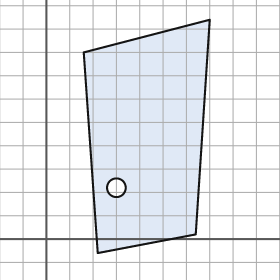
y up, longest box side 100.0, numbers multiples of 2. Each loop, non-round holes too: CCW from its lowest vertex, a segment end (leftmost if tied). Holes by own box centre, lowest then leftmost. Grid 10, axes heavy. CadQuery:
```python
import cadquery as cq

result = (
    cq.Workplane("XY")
    .moveTo(22.0, -6.0)
    .lineTo(64.0, 2.0)
    .lineTo(70.0, 94.0)
    .lineTo(16.0, 80.0)
    .close()
    .moveTo(30.0, 22.0)
    .circle(4.0)
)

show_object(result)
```